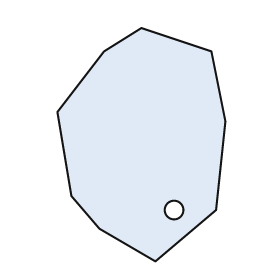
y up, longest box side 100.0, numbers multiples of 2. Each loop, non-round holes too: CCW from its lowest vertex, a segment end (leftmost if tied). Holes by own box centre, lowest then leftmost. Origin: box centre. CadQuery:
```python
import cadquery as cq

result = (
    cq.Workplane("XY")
    .moveTo(6.0, -50.0)
    .lineTo(32.0, -28.0)
    .lineTo(36.0, 10.0)
    .lineTo(30.0, 40.0)
    .lineTo(0.0, 50.0)
    .lineTo(-16.0, 40.0)
    .lineTo(-36.0, 14.0)
    .lineTo(-30.0, -22.0)
    .lineTo(-18.0, -36.0)
    .close()
    .moveTo(14.0, -28.0)
    .circle(4.0)
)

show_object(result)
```